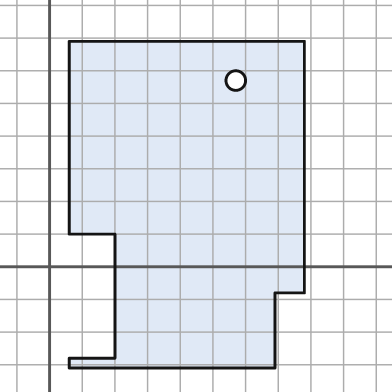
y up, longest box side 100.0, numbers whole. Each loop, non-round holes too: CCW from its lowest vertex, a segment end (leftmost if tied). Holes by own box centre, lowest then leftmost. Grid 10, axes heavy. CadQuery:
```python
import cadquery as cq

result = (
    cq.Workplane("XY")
    .moveTo(6.0, -31.0)
    .lineTo(69.0, -31.0)
    .lineTo(69.0, -8.0)
    .lineTo(78.0, -8.0)
    .lineTo(78.0, 69.0)
    .lineTo(6.0, 69.0)
    .lineTo(6.0, 10.0)
    .lineTo(20.0, 10.0)
    .lineTo(20.0, -28.0)
    .lineTo(6.0, -28.0)
    .close()
    .moveTo(57.0, 57.0)
    .circle(3.0)
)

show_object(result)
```